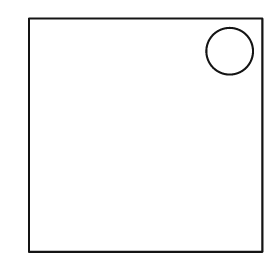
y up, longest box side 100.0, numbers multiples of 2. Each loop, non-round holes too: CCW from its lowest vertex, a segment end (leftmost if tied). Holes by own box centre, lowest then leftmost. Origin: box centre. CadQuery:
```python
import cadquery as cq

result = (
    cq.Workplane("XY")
    .moveTo(-50.0, -50.0)
    .lineTo(50.0, -50.0)
    .lineTo(50.0, 50.0)
    .lineTo(-50.0, 50.0)
    .close()
    .moveTo(36.0, 36.0)
    .circle(10.0)
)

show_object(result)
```